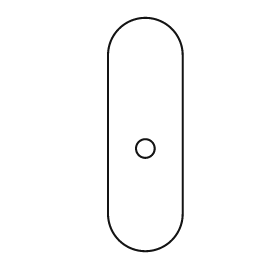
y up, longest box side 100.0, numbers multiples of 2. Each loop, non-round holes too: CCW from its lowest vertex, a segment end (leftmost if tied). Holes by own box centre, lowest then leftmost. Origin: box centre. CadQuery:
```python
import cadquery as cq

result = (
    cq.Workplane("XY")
    .moveTo(-16.0, -34.0)
    .threePointArc((0.0, -50.0), (16.0, -34.0))
    .lineTo(16.0, 34.0)
    .threePointArc((0.0, 50.0), (-16.0, 34.0))
    .close()
    .moveTo(0.0, -6.0)
    .circle(4.0)
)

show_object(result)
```